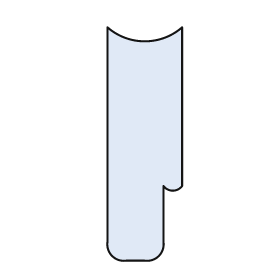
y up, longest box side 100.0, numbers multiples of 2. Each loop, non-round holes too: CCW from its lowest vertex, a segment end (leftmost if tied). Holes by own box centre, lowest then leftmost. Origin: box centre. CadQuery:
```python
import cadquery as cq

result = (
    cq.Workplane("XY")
    .moveTo(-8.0, -50.0)
    .lineTo(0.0, -50.0)
    .threePointArc((6.0, -48.0), (8.0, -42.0))
    .lineTo(8.0, -18.0)
    .threePointArc((12.0, -20.0), (16.0, -18.0))
    .lineTo(16.0, 50.0)
    .threePointArc((0.0, 44.0), (-16.0, 50.0))
    .lineTo(-16.0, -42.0)
    .threePointArc((-14.0, -48.0), (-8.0, -50.0))
    .close()
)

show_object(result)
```